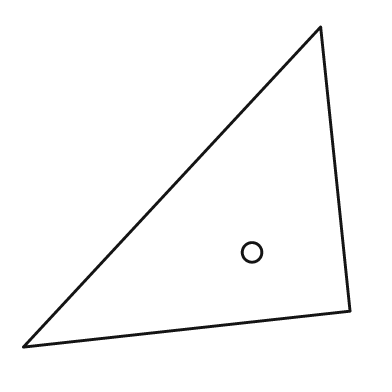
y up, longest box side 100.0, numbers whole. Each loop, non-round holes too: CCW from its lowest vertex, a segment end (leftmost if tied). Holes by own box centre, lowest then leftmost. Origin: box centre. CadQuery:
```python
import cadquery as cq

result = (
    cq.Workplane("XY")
    .moveTo(-50.0, -49.0)
    .lineTo(50.0, -38.0)
    .lineTo(41.0, 49.0)
    .close()
    .moveTo(20.0, -20.0)
    .circle(3.0)
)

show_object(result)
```